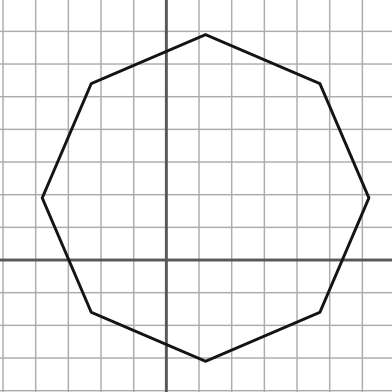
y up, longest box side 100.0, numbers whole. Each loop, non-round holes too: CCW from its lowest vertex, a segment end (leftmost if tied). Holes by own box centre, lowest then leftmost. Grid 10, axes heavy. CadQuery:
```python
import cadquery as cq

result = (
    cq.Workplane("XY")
    .moveTo(12.0, -31.0)
    .lineTo(47.0, -16.0)
    .lineTo(62.0, 19.0)
    .lineTo(47.0, 54.0)
    .lineTo(12.0, 69.0)
    .lineTo(-23.0, 54.0)
    .lineTo(-38.0, 19.0)
    .lineTo(-23.0, -16.0)
    .close()
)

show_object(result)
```